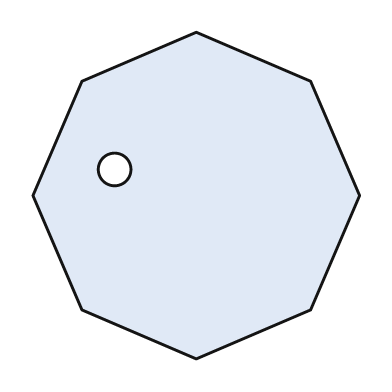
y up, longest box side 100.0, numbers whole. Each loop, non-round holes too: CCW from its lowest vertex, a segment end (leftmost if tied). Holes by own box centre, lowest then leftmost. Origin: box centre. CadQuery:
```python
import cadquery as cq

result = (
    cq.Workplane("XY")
    .moveTo(0.0, -50.0)
    .lineTo(35.0, -35.0)
    .lineTo(50.0, 0.0)
    .lineTo(35.0, 35.0)
    .lineTo(0.0, 50.0)
    .lineTo(-35.0, 35.0)
    .lineTo(-50.0, 0.0)
    .lineTo(-35.0, -35.0)
    .close()
    .moveTo(-25.0, 8.0)
    .circle(5.0)
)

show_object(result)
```